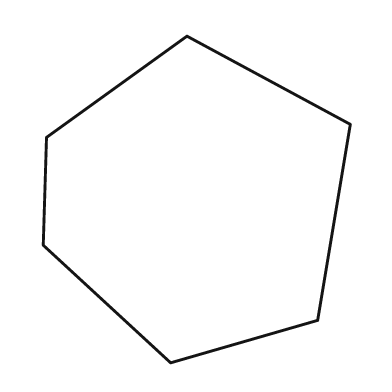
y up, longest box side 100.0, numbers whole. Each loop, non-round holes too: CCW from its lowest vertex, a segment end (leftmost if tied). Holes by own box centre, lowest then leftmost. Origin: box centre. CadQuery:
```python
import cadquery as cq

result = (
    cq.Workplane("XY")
    .moveTo(-8.0, -50.0)
    .lineTo(37.0, -37.0)
    .lineTo(47.0, 23.0)
    .lineTo(-3.0, 50.0)
    .lineTo(-46.0, 19.0)
    .lineTo(-47.0, -14.0)
    .close()
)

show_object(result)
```